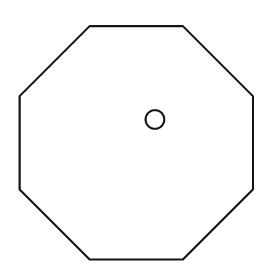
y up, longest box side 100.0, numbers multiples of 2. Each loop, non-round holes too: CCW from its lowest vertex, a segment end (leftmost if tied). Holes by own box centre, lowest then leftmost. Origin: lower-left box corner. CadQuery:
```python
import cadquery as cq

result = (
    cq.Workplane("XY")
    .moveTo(30.0, 0.0)
    .lineTo(70.0, 0.0)
    .lineTo(100.0, 30.0)
    .lineTo(100.0, 70.0)
    .lineTo(70.0, 100.0)
    .lineTo(30.0, 100.0)
    .lineTo(0.0, 70.0)
    .lineTo(0.0, 30.0)
    .close()
    .moveTo(58.0, 60.0)
    .circle(4.0)
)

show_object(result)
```